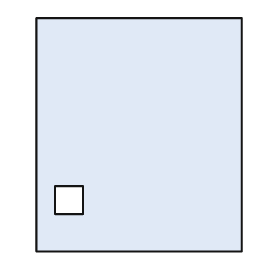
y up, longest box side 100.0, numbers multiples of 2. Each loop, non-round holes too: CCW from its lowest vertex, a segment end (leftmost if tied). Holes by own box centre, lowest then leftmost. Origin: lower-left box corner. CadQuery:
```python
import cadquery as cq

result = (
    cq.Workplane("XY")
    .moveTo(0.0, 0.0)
    .lineTo(88.0, 0.0)
    .lineTo(88.0, 100.0)
    .lineTo(0.0, 100.0)
    .close()
    .moveTo(8.0, 16.0)
    .lineTo(20.0, 16.0)
    .lineTo(20.0, 28.0)
    .lineTo(8.0, 28.0)
    .close()
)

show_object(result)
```